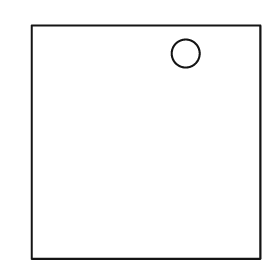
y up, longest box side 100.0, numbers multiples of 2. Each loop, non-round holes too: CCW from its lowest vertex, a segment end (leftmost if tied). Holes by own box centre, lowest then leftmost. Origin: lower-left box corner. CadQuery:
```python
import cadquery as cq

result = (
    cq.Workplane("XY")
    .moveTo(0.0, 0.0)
    .lineTo(98.0, 0.0)
    .lineTo(98.0, 100.0)
    .lineTo(0.0, 100.0)
    .close()
    .moveTo(66.0, 88.0)
    .circle(6.0)
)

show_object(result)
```